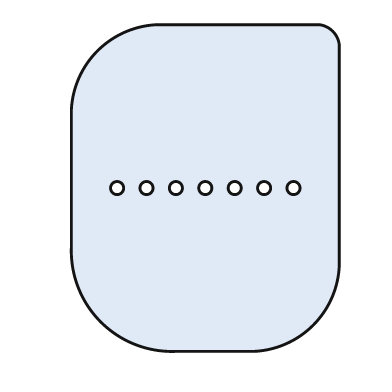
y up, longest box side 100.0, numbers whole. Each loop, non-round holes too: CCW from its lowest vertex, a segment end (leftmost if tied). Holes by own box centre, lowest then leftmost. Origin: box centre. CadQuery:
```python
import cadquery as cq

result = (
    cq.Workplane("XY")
    .moveTo(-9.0, -50.0)
    .lineTo(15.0, -50.0)
    .threePointArc((33.0, -42.0), (41.0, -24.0))
    .lineTo(41.0, 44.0)
    .threePointArc((39.0, 48.0), (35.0, 50.0))
    .lineTo(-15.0, 50.0)
    .threePointArc((-33.0, 42.0), (-41.0, 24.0))
    .lineTo(-41.0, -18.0)
    .threePointArc((-32.0, -41.0), (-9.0, -50.0))
    .close()
    .moveTo(-27.0, 0.0)
    .circle(2.0)
    .moveTo(-18.0, 0.0)
    .circle(2.0)
    .moveTo(-9.0, 0.0)
    .circle(2.0)
    .moveTo(0.0, 0.0)
    .circle(2.0)
    .moveTo(9.0, 0.0)
    .circle(2.0)
    .moveTo(18.0, 0.0)
    .circle(2.0)
    .moveTo(27.0, 0.0)
    .circle(2.0)
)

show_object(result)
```